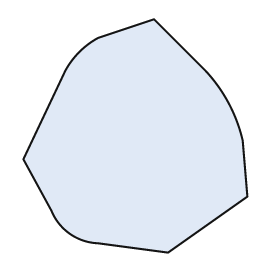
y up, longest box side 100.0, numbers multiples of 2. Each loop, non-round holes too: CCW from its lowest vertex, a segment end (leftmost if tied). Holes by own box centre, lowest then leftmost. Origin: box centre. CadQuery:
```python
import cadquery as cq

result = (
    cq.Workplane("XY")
    .moveTo(14.0, -50.0)
    .lineTo(48.0, -26.0)
    .lineTo(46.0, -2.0)
    .threePointArc((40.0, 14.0), (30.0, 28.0))
    .lineTo(8.0, 50.0)
    .lineTo(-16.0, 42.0)
    .threePointArc((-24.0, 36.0), (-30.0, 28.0))
    .lineTo(-48.0, -10.0)
    .lineTo(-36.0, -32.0)
    .threePointArc((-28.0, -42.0), (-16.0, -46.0))
    .close()
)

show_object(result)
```